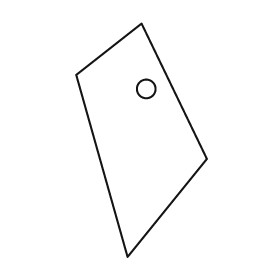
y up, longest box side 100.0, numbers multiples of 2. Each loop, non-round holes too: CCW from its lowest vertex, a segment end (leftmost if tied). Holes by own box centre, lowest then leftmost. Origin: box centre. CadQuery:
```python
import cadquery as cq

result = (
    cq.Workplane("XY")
    .moveTo(-6.0, -50.0)
    .lineTo(28.0, -8.0)
    .lineTo(0.0, 50.0)
    .lineTo(-28.0, 28.0)
    .close()
    .moveTo(2.0, 22.0)
    .circle(4.0)
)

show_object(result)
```